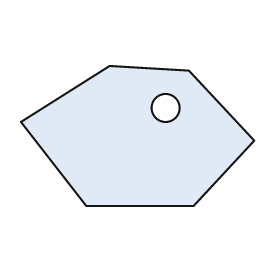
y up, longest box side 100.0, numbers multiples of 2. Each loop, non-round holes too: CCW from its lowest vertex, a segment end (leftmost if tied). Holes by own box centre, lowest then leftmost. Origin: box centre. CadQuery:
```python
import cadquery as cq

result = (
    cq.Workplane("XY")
    .moveTo(-22.0, -30.0)
    .lineTo(24.0, -30.0)
    .lineTo(50.0, -2.0)
    .lineTo(22.0, 28.0)
    .lineTo(-12.0, 30.0)
    .lineTo(-50.0, 6.0)
    .close()
    .moveTo(12.0, 12.0)
    .circle(6.0)
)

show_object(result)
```